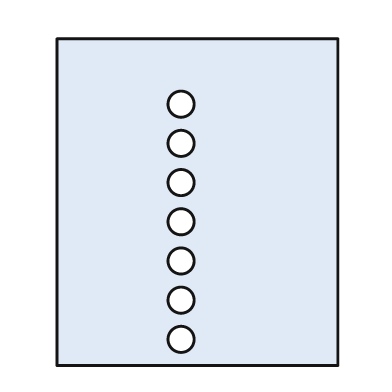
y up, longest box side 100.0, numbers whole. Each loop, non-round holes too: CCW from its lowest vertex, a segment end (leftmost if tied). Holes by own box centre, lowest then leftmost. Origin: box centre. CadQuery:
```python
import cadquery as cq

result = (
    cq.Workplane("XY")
    .moveTo(-43.0, -50.0)
    .lineTo(43.0, -50.0)
    .lineTo(43.0, 50.0)
    .lineTo(-43.0, 50.0)
    .close()
    .moveTo(-5.0, -42.0)
    .circle(4.0)
    .moveTo(-5.0, -30.0)
    .circle(4.0)
    .moveTo(-5.0, -18.0)
    .circle(4.0)
    .moveTo(-5.0, -6.0)
    .circle(4.0)
    .moveTo(-5.0, 6.0)
    .circle(4.0)
    .moveTo(-5.0, 18.0)
    .circle(4.0)
    .moveTo(-5.0, 30.0)
    .circle(4.0)
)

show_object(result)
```